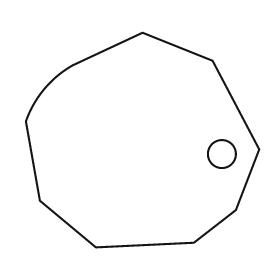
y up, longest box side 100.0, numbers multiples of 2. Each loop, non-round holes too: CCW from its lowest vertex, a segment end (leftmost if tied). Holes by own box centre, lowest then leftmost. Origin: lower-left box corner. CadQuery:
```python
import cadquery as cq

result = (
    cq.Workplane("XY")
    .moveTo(30.0, 0.0)
    .lineTo(72.0, 2.0)
    .lineTo(90.0, 16.0)
    .lineTo(100.0, 42.0)
    .lineTo(80.0, 80.0)
    .lineTo(50.0, 92.0)
    .lineTo(20.0, 78.0)
    .threePointArc((8.0, 68.0), (0.0, 54.0))
    .lineTo(6.0, 20.0)
    .close()
    .moveTo(84.0, 40.0)
    .circle(6.0)
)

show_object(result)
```